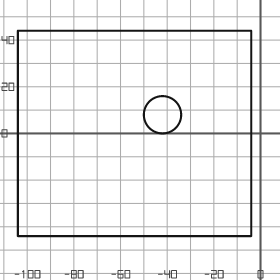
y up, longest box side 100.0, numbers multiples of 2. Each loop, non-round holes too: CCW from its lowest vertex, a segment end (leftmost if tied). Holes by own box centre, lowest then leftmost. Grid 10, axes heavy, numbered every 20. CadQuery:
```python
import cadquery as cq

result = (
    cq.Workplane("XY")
    .moveTo(-104.0, -44.0)
    .lineTo(-4.0, -44.0)
    .lineTo(-4.0, 44.0)
    .lineTo(-104.0, 44.0)
    .close()
    .moveTo(-42.0, 8.0)
    .circle(8.0)
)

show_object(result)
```